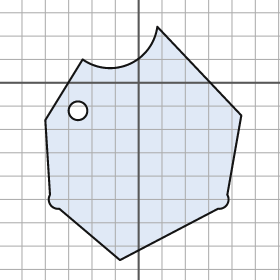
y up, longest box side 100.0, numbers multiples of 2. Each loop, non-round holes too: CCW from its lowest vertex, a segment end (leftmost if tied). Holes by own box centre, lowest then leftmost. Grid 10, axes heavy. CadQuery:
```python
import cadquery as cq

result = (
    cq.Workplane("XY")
    .moveTo(-8.0, -76.0)
    .lineTo(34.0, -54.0)
    .threePointArc((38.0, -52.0), (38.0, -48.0))
    .lineTo(44.0, -14.0)
    .lineTo(8.0, 24.0)
    .threePointArc((-4.0, 8.0), (-24.0, 10.0))
    .lineTo(-40.0, -16.0)
    .lineTo(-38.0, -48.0)
    .threePointArc((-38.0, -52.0), (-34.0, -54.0))
    .close()
    .moveTo(-26.0, -12.0)
    .circle(4.0)
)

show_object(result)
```